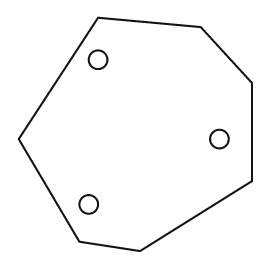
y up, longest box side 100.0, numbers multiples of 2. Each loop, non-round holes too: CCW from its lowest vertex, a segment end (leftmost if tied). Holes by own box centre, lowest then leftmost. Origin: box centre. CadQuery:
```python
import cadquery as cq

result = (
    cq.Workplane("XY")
    .moveTo(2.0, -50.0)
    .lineTo(50.0, -20.0)
    .lineTo(50.0, 22.0)
    .lineTo(28.0, 46.0)
    .lineTo(-16.0, 50.0)
    .lineTo(-50.0, -2.0)
    .lineTo(-24.0, -46.0)
    .close()
    .moveTo(-20.0, -30.0)
    .circle(4.0)
    .moveTo(36.0, -2.0)
    .circle(4.0)
    .moveTo(-16.0, 32.0)
    .circle(4.0)
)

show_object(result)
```